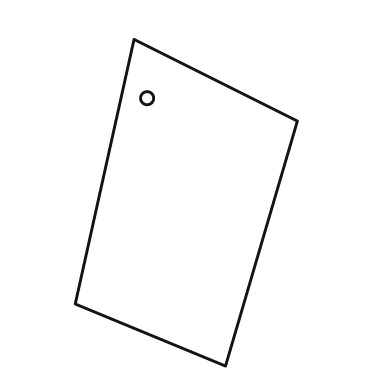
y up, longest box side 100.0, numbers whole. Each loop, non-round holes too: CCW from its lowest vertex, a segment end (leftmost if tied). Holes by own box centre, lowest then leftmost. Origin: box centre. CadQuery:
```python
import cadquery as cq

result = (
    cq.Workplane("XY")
    .moveTo(12.0, -50.0)
    .lineTo(34.0, 25.0)
    .lineTo(-16.0, 50.0)
    .lineTo(-34.0, -31.0)
    .close()
    .moveTo(-12.0, 32.0)
    .circle(2.0)
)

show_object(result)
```